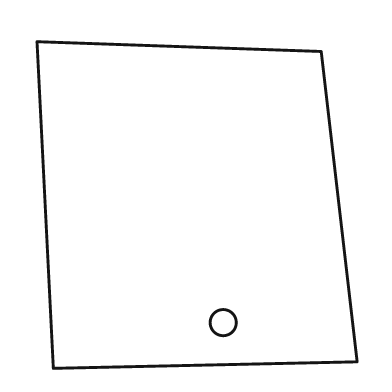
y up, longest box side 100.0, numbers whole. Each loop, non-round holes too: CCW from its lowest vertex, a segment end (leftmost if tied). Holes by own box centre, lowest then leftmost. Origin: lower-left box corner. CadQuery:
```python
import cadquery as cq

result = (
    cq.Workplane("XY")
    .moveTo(5.0, 0.0)
    .lineTo(98.0, 2.0)
    .lineTo(87.0, 97.0)
    .lineTo(0.0, 100.0)
    .close()
    .moveTo(57.0, 14.0)
    .circle(4.0)
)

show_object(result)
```